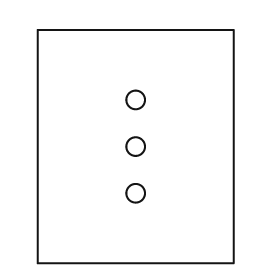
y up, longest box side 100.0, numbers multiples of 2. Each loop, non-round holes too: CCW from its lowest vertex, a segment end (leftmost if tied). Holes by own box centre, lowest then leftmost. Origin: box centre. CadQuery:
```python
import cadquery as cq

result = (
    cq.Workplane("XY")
    .moveTo(-42.0, -50.0)
    .lineTo(42.0, -50.0)
    .lineTo(42.0, 50.0)
    .lineTo(-42.0, 50.0)
    .close()
    .moveTo(0.0, -20.0)
    .circle(4.0)
    .moveTo(0.0, 0.0)
    .circle(4.0)
    .moveTo(0.0, 20.0)
    .circle(4.0)
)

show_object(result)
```